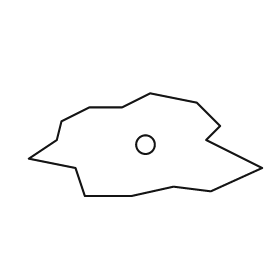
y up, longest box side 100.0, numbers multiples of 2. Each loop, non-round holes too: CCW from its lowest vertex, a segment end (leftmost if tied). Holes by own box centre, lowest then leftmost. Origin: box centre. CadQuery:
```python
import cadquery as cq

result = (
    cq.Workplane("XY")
    .moveTo(-26.0, -22.0)
    .lineTo(-6.0, -22.0)
    .lineTo(12.0, -18.0)
    .lineTo(28.0, -20.0)
    .lineTo(50.0, -10.0)
    .lineTo(26.0, 2.0)
    .lineTo(32.0, 8.0)
    .lineTo(22.0, 18.0)
    .lineTo(2.0, 22.0)
    .lineTo(-10.0, 16.0)
    .lineTo(-24.0, 16.0)
    .lineTo(-36.0, 10.0)
    .lineTo(-38.0, 2.0)
    .lineTo(-50.0, -6.0)
    .lineTo(-30.0, -10.0)
    .close()
    .moveTo(0.0, 0.0)
    .circle(4.0)
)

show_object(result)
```